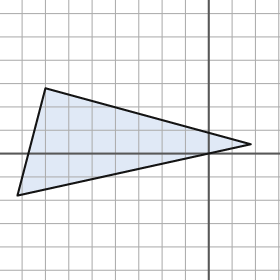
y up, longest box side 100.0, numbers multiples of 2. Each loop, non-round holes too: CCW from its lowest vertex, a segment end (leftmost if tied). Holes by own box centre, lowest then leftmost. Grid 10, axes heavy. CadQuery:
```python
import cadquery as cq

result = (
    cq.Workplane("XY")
    .moveTo(-82.0, -18.0)
    .lineTo(18.0, 4.0)
    .lineTo(-70.0, 28.0)
    .close()
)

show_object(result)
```